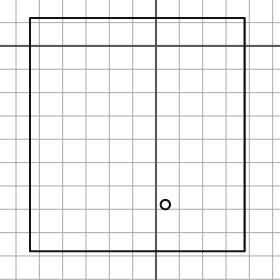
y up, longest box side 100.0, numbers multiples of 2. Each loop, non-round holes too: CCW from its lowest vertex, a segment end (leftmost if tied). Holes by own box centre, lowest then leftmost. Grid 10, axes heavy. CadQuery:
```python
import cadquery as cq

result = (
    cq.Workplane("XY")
    .moveTo(-54.0, -88.0)
    .lineTo(38.0, -88.0)
    .lineTo(38.0, 12.0)
    .lineTo(-54.0, 12.0)
    .close()
    .moveTo(4.0, -68.0)
    .circle(2.0)
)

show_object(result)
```